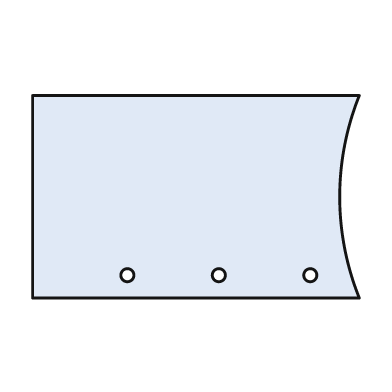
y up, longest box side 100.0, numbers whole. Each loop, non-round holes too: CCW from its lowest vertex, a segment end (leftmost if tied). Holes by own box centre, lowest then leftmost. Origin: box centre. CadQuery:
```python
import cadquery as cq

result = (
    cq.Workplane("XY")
    .moveTo(-50.0, -31.0)
    .lineTo(50.0, -31.0)
    .threePointArc((44.0, 0.0), (50.0, 31.0))
    .lineTo(-50.0, 31.0)
    .close()
    .moveTo(-21.0, -24.0)
    .circle(2.0)
    .moveTo(7.0, -24.0)
    .circle(2.0)
    .moveTo(35.0, -24.0)
    .circle(2.0)
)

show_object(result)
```